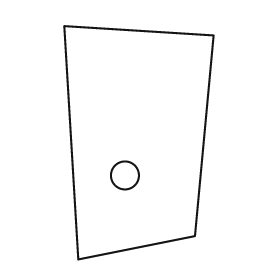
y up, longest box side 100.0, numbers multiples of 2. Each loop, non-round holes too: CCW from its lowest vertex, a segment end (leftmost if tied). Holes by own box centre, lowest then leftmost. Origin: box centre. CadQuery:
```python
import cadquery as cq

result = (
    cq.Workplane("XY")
    .moveTo(-26.0, -50.0)
    .lineTo(24.0, -40.0)
    .lineTo(32.0, 46.0)
    .lineTo(-32.0, 50.0)
    .close()
    .moveTo(-6.0, -14.0)
    .circle(6.0)
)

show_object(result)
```